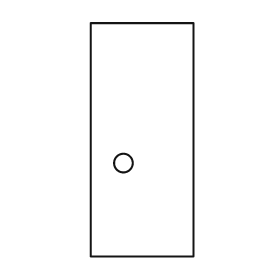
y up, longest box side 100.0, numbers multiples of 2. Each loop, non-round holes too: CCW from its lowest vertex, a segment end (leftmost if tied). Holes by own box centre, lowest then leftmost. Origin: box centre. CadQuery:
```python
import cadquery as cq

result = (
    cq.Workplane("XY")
    .moveTo(-22.0, -50.0)
    .lineTo(22.0, -50.0)
    .lineTo(22.0, 50.0)
    .lineTo(-22.0, 50.0)
    .close()
    .moveTo(-8.0, -10.0)
    .circle(4.0)
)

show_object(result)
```